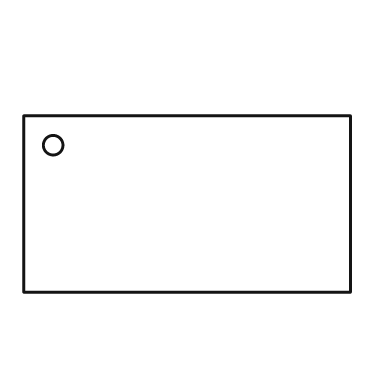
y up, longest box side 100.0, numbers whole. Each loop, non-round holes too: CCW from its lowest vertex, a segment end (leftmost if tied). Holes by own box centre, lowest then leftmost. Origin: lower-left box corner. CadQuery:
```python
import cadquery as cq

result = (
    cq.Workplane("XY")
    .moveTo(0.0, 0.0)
    .lineTo(100.0, 0.0)
    .lineTo(100.0, 54.0)
    .lineTo(0.0, 54.0)
    .close()
    .moveTo(9.0, 45.0)
    .circle(3.0)
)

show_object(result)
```